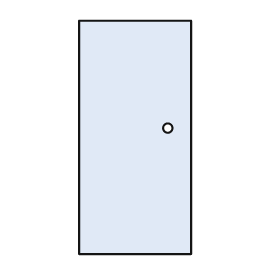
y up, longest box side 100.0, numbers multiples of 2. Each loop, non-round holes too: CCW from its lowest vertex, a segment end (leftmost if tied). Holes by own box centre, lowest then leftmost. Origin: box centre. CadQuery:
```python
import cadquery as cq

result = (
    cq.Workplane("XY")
    .moveTo(-24.0, -50.0)
    .lineTo(24.0, -50.0)
    .lineTo(24.0, 50.0)
    .lineTo(-24.0, 50.0)
    .close()
    .moveTo(14.0, 4.0)
    .circle(2.0)
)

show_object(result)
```